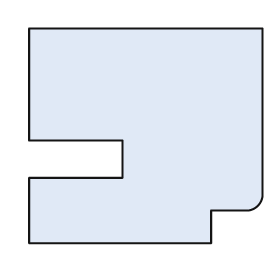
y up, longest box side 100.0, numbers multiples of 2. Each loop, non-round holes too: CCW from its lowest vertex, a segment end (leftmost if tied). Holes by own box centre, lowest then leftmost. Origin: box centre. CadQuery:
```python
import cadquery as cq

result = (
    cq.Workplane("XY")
    .moveTo(-50.0, -46.0)
    .lineTo(28.0, -46.0)
    .lineTo(28.0, -32.0)
    .lineTo(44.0, -32.0)
    .threePointArc((48.0, -30.0), (50.0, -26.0))
    .lineTo(50.0, 46.0)
    .lineTo(-50.0, 46.0)
    .lineTo(-50.0, -2.0)
    .lineTo(-10.0, -2.0)
    .lineTo(-10.0, -18.0)
    .lineTo(-50.0, -18.0)
    .close()
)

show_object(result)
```